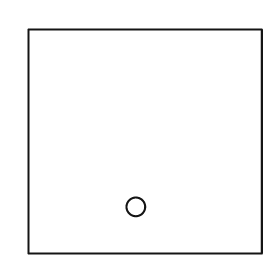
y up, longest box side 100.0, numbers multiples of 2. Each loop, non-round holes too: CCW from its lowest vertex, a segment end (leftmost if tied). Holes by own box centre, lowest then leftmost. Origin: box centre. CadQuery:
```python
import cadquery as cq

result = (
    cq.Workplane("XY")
    .moveTo(-50.0, -48.0)
    .lineTo(50.0, -48.0)
    .lineTo(50.0, 48.0)
    .lineTo(-50.0, 48.0)
    .close()
    .moveTo(-4.0, -28.0)
    .circle(4.0)
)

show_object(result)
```